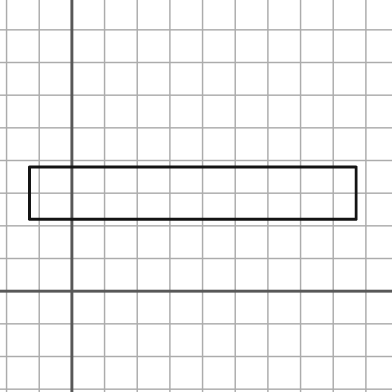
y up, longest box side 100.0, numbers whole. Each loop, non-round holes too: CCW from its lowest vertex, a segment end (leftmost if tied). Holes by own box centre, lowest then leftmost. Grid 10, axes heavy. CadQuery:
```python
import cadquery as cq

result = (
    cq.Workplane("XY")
    .moveTo(-13.0, 22.0)
    .lineTo(87.0, 22.0)
    .lineTo(87.0, 38.0)
    .lineTo(-13.0, 38.0)
    .close()
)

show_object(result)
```